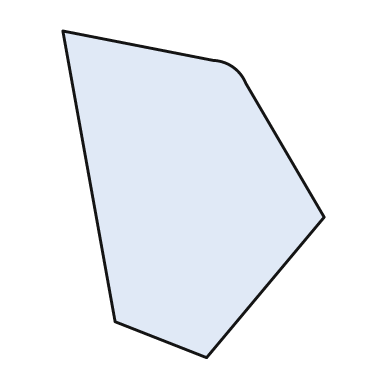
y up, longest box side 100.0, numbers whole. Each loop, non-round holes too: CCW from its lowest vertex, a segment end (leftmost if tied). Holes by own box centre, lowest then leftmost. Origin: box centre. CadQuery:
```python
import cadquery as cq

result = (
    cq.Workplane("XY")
    .moveTo(4.0, -50.0)
    .lineTo(40.0, -7.0)
    .lineTo(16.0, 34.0)
    .threePointArc((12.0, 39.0), (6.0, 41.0))
    .lineTo(-40.0, 50.0)
    .lineTo(-24.0, -39.0)
    .close()
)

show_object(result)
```